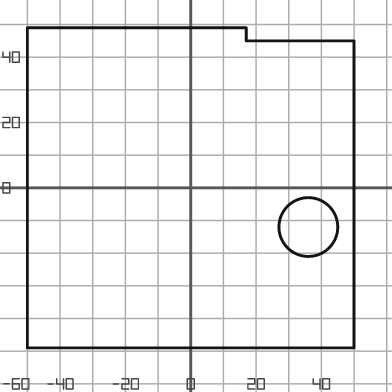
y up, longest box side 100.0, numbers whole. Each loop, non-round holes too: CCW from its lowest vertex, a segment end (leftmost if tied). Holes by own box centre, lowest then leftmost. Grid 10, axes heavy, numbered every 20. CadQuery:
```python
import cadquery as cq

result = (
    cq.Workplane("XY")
    .moveTo(-50.0, -49.0)
    .lineTo(50.0, -49.0)
    .lineTo(50.0, 45.0)
    .lineTo(17.0, 45.0)
    .lineTo(17.0, 49.0)
    .lineTo(-50.0, 49.0)
    .close()
    .moveTo(36.0, -12.0)
    .circle(9.0)
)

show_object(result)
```